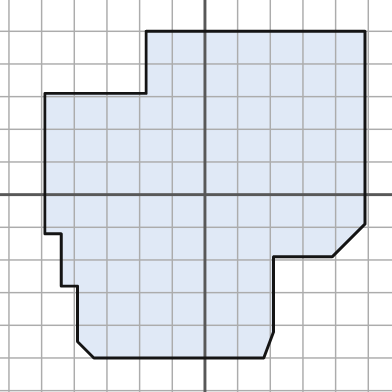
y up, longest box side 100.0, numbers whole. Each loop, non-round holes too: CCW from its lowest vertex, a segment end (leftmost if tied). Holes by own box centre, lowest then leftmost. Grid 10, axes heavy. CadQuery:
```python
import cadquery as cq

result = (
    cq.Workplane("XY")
    .moveTo(-34.0, -50.0)
    .lineTo(18.0, -50.0)
    .lineTo(21.0, -42.0)
    .lineTo(21.0, -19.0)
    .lineTo(39.0, -19.0)
    .lineTo(49.0, -9.0)
    .lineTo(49.0, 50.0)
    .lineTo(-18.0, 50.0)
    .lineTo(-18.0, 31.0)
    .lineTo(-49.0, 31.0)
    .lineTo(-49.0, -12.0)
    .lineTo(-44.0, -12.0)
    .lineTo(-44.0, -28.0)
    .lineTo(-39.0, -28.0)
    .lineTo(-39.0, -45.0)
    .close()
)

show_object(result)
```